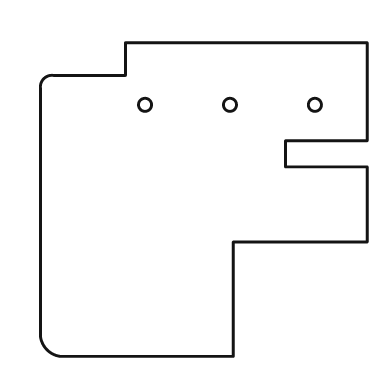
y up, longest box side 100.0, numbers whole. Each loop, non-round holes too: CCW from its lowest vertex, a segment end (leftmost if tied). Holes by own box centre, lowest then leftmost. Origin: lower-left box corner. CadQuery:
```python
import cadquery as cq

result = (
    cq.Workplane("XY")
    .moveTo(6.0, 0.0)
    .lineTo(59.0, 0.0)
    .lineTo(59.0, 35.0)
    .lineTo(100.0, 35.0)
    .lineTo(100.0, 58.0)
    .lineTo(75.0, 58.0)
    .lineTo(75.0, 66.0)
    .lineTo(100.0, 66.0)
    .lineTo(100.0, 96.0)
    .lineTo(26.0, 96.0)
    .lineTo(26.0, 86.0)
    .lineTo(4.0, 86.0)
    .threePointArc((1.0, 85.0), (0.0, 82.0))
    .lineTo(0.0, 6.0)
    .threePointArc((2.0, 2.0), (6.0, 0.0))
    .close()
    .moveTo(32.0, 77.0)
    .circle(2.0)
    .moveTo(58.0, 77.0)
    .circle(2.0)
    .moveTo(84.0, 77.0)
    .circle(2.0)
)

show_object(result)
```